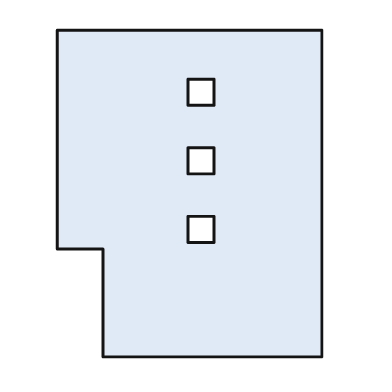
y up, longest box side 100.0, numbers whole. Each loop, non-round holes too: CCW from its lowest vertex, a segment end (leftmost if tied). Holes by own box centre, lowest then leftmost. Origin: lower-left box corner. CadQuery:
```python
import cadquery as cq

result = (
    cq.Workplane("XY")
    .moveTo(14.0, 0.0)
    .lineTo(81.0, 0.0)
    .lineTo(81.0, 100.0)
    .lineTo(0.0, 100.0)
    .lineTo(0.0, 33.0)
    .lineTo(14.0, 33.0)
    .close()
    .moveTo(40.0, 35.0)
    .lineTo(48.0, 35.0)
    .lineTo(48.0, 43.0)
    .lineTo(40.0, 43.0)
    .close()
    .moveTo(40.0, 56.0)
    .lineTo(48.0, 56.0)
    .lineTo(48.0, 64.0)
    .lineTo(40.0, 64.0)
    .close()
    .moveTo(40.0, 77.0)
    .lineTo(48.0, 77.0)
    .lineTo(48.0, 85.0)
    .lineTo(40.0, 85.0)
    .close()
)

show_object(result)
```